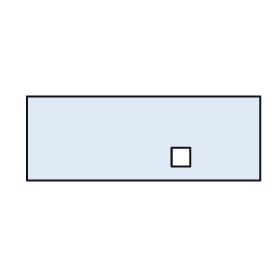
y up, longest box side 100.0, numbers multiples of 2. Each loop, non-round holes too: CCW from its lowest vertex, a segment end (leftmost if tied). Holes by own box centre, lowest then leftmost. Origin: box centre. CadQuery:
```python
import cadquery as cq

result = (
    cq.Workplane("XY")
    .moveTo(-50.0, -18.0)
    .lineTo(50.0, -18.0)
    .lineTo(50.0, 18.0)
    .lineTo(-50.0, 18.0)
    .close()
    .moveTo(12.0, -12.0)
    .lineTo(20.0, -12.0)
    .lineTo(20.0, -4.0)
    .lineTo(12.0, -4.0)
    .close()
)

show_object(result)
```